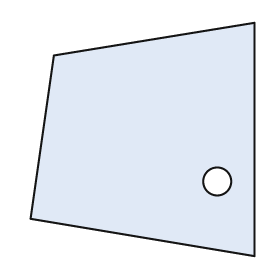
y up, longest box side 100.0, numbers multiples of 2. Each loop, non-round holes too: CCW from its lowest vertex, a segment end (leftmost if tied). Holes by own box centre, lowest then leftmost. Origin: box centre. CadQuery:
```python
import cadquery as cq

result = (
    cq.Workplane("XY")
    .moveTo(48.0, -50.0)
    .lineTo(48.0, 50.0)
    .lineTo(-38.0, 36.0)
    .lineTo(-48.0, -34.0)
    .close()
    .moveTo(32.0, -18.0)
    .circle(6.0)
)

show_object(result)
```